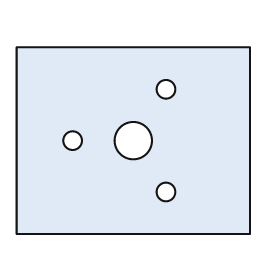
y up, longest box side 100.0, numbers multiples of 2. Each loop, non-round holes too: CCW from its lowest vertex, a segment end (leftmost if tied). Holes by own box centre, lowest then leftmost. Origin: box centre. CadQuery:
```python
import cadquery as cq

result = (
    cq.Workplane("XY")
    .moveTo(-50.0, -40.0)
    .lineTo(50.0, -40.0)
    .lineTo(50.0, 40.0)
    .lineTo(-50.0, 40.0)
    .close()
    .moveTo(14.0, -22.0)
    .circle(4.0)
    .moveTo(-26.0, 0.0)
    .circle(4.0)
    .moveTo(0.0, 0.0)
    .circle(8.0)
    .moveTo(14.0, 22.0)
    .circle(4.0)
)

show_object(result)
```